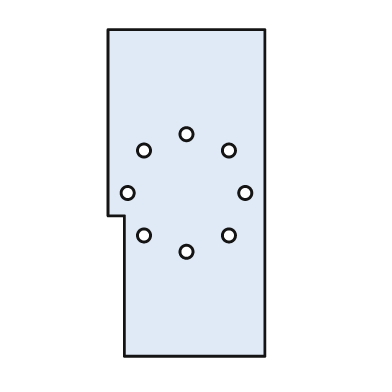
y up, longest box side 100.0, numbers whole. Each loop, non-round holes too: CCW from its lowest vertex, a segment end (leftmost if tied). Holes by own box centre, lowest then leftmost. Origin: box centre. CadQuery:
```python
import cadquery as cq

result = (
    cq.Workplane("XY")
    .moveTo(-19.0, -50.0)
    .lineTo(24.0, -50.0)
    .lineTo(24.0, 50.0)
    .lineTo(-24.0, 50.0)
    .lineTo(-24.0, -7.0)
    .lineTo(-19.0, -7.0)
    .close()
    .moveTo(0.0, -18.0)
    .circle(2.0)
    .moveTo(-13.0, -13.0)
    .circle(2.0)
    .moveTo(13.0, -13.0)
    .circle(2.0)
    .moveTo(-18.0, 0.0)
    .circle(2.0)
    .moveTo(18.0, 0.0)
    .circle(2.0)
    .moveTo(-13.0, 13.0)
    .circle(2.0)
    .moveTo(13.0, 13.0)
    .circle(2.0)
    .moveTo(0.0, 18.0)
    .circle(2.0)
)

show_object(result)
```